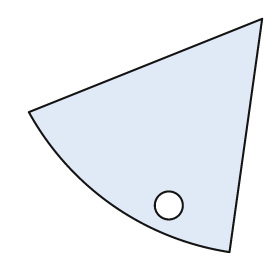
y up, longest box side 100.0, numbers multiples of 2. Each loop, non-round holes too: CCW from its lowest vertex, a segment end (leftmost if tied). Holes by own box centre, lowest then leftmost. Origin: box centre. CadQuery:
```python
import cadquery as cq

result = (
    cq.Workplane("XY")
    .moveTo(36.0, -50.0)
    .lineTo(50.0, 50.0)
    .lineTo(-50.0, 10.0)
    .threePointArc((-14.0, -30.0), (36.0, -50.0))
    .close()
    .moveTo(10.0, -30.0)
    .circle(6.0)
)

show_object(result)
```